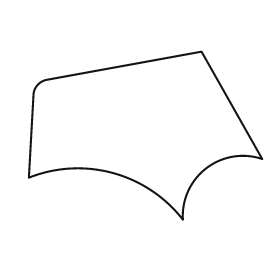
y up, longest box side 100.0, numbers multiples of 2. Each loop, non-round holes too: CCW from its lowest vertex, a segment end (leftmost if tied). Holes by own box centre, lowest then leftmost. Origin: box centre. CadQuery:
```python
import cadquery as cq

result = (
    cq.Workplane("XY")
    .moveTo(16.0, -36.0)
    .threePointArc((26.0, -14.0), (50.0, -10.0))
    .lineTo(24.0, 36.0)
    .lineTo(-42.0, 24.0)
    .threePointArc((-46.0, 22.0), (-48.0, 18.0))
    .lineTo(-50.0, -18.0)
    .threePointArc((-14.0, -16.0), (16.0, -36.0))
    .close()
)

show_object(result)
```